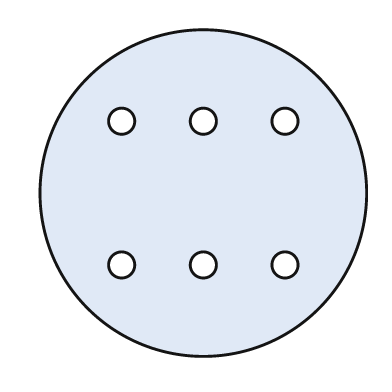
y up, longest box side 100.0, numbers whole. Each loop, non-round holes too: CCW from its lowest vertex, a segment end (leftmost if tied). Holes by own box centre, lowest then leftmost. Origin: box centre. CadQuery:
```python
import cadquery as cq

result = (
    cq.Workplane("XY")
    .moveTo(0.0, 0.0)
    .circle(50.0)
    .moveTo(-25.0, -22.0)
    .circle(4.0)
    .moveTo(0.0, -22.0)
    .circle(4.0)
    .moveTo(25.0, -22.0)
    .circle(4.0)
    .moveTo(-25.0, 22.0)
    .circle(4.0)
    .moveTo(0.0, 22.0)
    .circle(4.0)
    .moveTo(25.0, 22.0)
    .circle(4.0)
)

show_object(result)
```